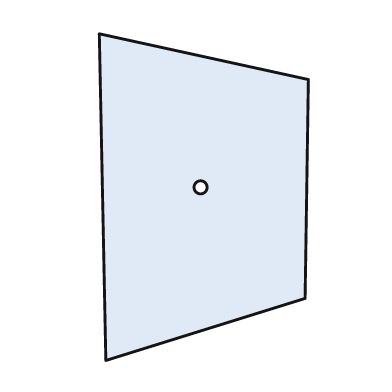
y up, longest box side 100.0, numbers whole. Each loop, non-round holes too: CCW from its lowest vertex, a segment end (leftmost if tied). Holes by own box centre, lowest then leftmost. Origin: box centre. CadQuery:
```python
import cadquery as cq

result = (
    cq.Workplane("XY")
    .moveTo(-30.0, -50.0)
    .lineTo(31.0, -31.0)
    .lineTo(32.0, 36.0)
    .lineTo(-32.0, 50.0)
    .close()
    .moveTo(-1.0, 3.0)
    .circle(2.0)
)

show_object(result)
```